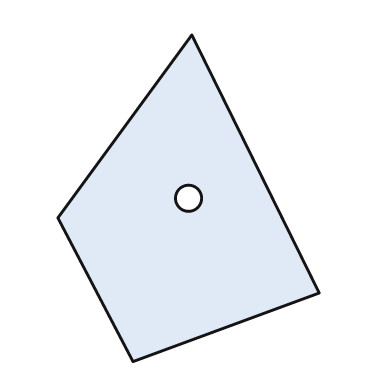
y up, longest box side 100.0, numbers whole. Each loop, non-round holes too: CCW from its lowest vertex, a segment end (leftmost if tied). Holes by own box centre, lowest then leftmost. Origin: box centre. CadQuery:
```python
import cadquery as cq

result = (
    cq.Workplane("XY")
    .moveTo(-17.0, -50.0)
    .lineTo(40.0, -29.0)
    .lineTo(1.0, 50.0)
    .lineTo(-40.0, -6.0)
    .close()
    .moveTo(0.0, 0.0)
    .circle(4.0)
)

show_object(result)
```